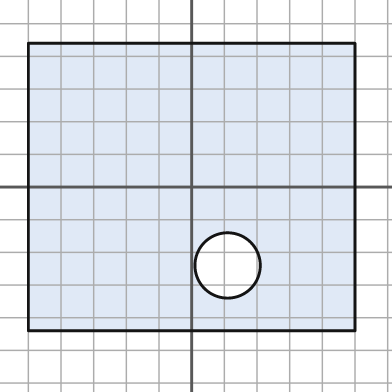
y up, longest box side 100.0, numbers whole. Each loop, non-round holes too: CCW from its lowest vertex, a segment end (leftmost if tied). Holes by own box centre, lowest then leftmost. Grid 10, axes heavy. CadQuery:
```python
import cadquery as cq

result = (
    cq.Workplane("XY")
    .moveTo(-50.0, -44.0)
    .lineTo(50.0, -44.0)
    .lineTo(50.0, 44.0)
    .lineTo(-50.0, 44.0)
    .close()
    .moveTo(11.0, -24.0)
    .circle(10.0)
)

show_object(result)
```